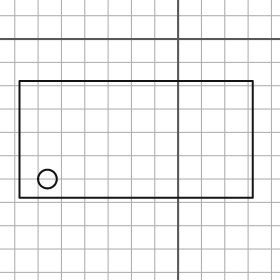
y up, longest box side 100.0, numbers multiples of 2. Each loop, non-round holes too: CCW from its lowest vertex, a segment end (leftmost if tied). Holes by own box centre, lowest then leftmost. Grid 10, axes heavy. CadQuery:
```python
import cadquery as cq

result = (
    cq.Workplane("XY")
    .moveTo(-68.0, -68.0)
    .lineTo(32.0, -68.0)
    .lineTo(32.0, -18.0)
    .lineTo(-68.0, -18.0)
    .close()
    .moveTo(-56.0, -60.0)
    .circle(4.0)
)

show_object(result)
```